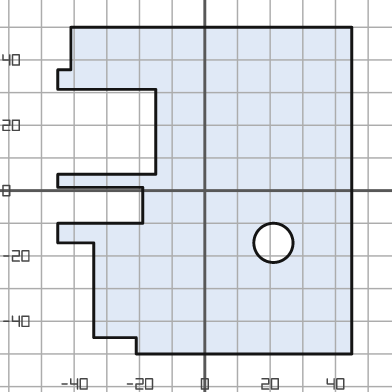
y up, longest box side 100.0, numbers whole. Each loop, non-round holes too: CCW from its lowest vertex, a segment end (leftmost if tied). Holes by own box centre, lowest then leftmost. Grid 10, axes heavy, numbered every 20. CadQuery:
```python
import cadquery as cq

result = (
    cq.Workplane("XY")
    .moveTo(-21.0, -50.0)
    .lineTo(45.0, -50.0)
    .lineTo(45.0, 50.0)
    .lineTo(-41.0, 50.0)
    .lineTo(-41.0, 37.0)
    .lineTo(-45.0, 37.0)
    .lineTo(-45.0, 31.0)
    .lineTo(-15.0, 31.0)
    .lineTo(-15.0, 5.0)
    .lineTo(-45.0, 5.0)
    .lineTo(-45.0, 1.0)
    .lineTo(-19.0, 1.0)
    .lineTo(-19.0, -10.0)
    .lineTo(-45.0, -10.0)
    .lineTo(-45.0, -16.0)
    .lineTo(-34.0, -16.0)
    .lineTo(-34.0, -45.0)
    .lineTo(-21.0, -45.0)
    .close()
    .moveTo(21.0, -16.0)
    .circle(6.0)
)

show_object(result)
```